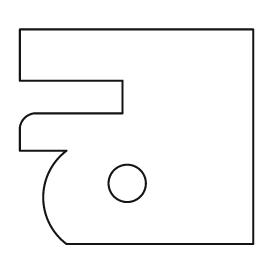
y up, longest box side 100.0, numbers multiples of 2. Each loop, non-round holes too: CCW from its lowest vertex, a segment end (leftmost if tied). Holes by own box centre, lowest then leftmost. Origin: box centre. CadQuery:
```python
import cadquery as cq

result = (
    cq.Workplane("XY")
    .moveTo(-30.0, -46.0)
    .lineTo(50.0, -46.0)
    .lineTo(50.0, 46.0)
    .lineTo(-50.0, 46.0)
    .lineTo(-50.0, 24.0)
    .lineTo(-6.0, 24.0)
    .lineTo(-6.0, 10.0)
    .lineTo(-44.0, 10.0)
    .threePointArc((-48.0, 8.0), (-50.0, 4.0))
    .lineTo(-50.0, -6.0)
    .lineTo(-30.0, -6.0)
    .threePointArc((-40.0, -26.0), (-30.0, -46.0))
    .close()
    .moveTo(-4.0, -20.0)
    .circle(8.0)
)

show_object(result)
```